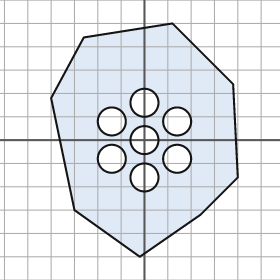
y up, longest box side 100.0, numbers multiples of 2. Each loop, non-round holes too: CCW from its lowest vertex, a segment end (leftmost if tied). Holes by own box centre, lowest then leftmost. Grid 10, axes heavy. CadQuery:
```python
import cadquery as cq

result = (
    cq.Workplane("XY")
    .moveTo(-2.0, -50.0)
    .lineTo(24.0, -32.0)
    .lineTo(40.0, -16.0)
    .lineTo(38.0, 24.0)
    .lineTo(12.0, 50.0)
    .lineTo(-26.0, 44.0)
    .lineTo(-40.0, 18.0)
    .lineTo(-30.0, -30.0)
    .close()
    .moveTo(0.0, -16.0)
    .circle(6.0)
    .moveTo(-14.0, -8.0)
    .circle(6.0)
    .moveTo(14.0, -8.0)
    .circle(6.0)
    .moveTo(0.0, 0.0)
    .circle(6.0)
    .moveTo(-14.0, 8.0)
    .circle(6.0)
    .moveTo(14.0, 8.0)
    .circle(6.0)
    .moveTo(0.0, 16.0)
    .circle(6.0)
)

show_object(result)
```